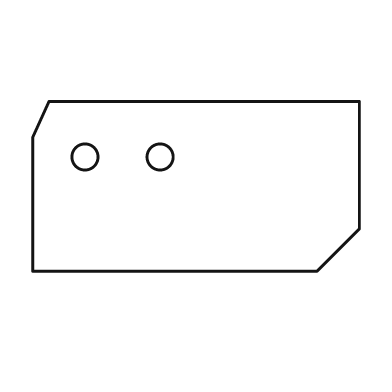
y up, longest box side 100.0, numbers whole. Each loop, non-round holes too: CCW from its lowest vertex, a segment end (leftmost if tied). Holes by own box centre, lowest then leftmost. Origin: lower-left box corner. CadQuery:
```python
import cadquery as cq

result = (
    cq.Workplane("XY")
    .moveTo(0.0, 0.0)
    .lineTo(87.0, 0.0)
    .lineTo(100.0, 13.0)
    .lineTo(100.0, 52.0)
    .lineTo(5.0, 52.0)
    .lineTo(0.0, 41.0)
    .close()
    .moveTo(16.0, 35.0)
    .circle(4.0)
    .moveTo(39.0, 35.0)
    .circle(4.0)
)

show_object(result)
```